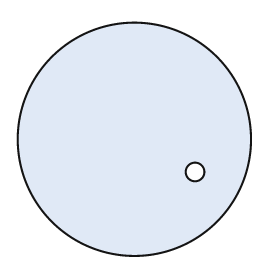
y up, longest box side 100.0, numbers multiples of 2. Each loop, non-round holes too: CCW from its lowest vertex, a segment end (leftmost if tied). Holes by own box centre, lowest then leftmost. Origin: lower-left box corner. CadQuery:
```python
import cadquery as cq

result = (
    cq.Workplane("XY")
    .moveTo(50.0, 50.0)
    .circle(50.0)
    .moveTo(76.0, 36.0)
    .circle(4.0)
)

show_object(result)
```